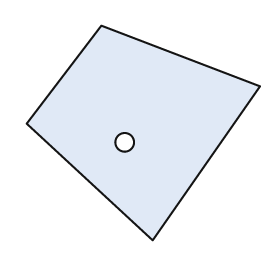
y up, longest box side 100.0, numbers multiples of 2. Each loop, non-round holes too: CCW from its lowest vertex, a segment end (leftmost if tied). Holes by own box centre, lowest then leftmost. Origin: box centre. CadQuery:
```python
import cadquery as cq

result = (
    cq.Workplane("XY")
    .moveTo(4.0, -46.0)
    .lineTo(50.0, 20.0)
    .lineTo(-18.0, 46.0)
    .lineTo(-50.0, 4.0)
    .close()
    .moveTo(-8.0, -4.0)
    .circle(4.0)
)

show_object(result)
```